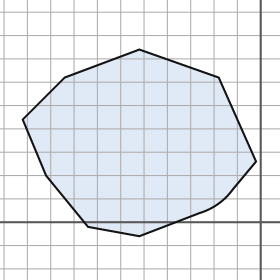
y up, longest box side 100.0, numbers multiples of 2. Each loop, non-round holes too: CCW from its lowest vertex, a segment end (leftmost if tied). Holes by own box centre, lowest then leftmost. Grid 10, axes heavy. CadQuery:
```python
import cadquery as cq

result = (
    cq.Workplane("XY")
    .moveTo(-52.0, -6.0)
    .lineTo(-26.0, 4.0)
    .threePointArc((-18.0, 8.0), (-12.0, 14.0))
    .lineTo(-2.0, 26.0)
    .lineTo(-18.0, 62.0)
    .lineTo(-52.0, 74.0)
    .lineTo(-84.0, 62.0)
    .lineTo(-102.0, 44.0)
    .lineTo(-92.0, 20.0)
    .lineTo(-74.0, -2.0)
    .close()
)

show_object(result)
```